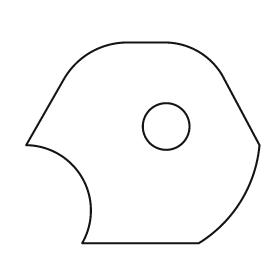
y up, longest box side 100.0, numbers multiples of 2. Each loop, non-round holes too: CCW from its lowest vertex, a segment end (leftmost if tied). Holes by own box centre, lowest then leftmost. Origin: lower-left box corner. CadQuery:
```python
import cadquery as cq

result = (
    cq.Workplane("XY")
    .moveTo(24.0, 0.0)
    .lineTo(74.0, 0.0)
    .threePointArc((92.0, 18.0), (100.0, 42.0))
    .lineTo(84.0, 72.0)
    .threePointArc((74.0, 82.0), (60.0, 86.0))
    .lineTo(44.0, 86.0)
    .threePointArc((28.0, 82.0), (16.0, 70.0))
    .lineTo(0.0, 42.0)
    .threePointArc((24.0, 28.0), (24.0, 0.0))
    .close()
    .moveTo(60.0, 50.0)
    .circle(10.0)
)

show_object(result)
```